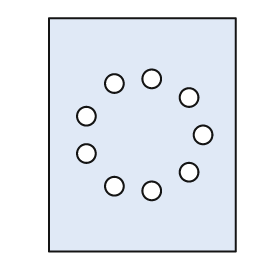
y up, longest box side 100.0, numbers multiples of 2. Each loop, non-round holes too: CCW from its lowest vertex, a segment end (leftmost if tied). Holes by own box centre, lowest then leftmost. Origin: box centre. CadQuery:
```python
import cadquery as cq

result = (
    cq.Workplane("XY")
    .moveTo(-40.0, -50.0)
    .lineTo(40.0, -50.0)
    .lineTo(40.0, 50.0)
    .lineTo(-40.0, 50.0)
    .close()
    .moveTo(4.0, -24.0)
    .circle(4.0)
    .moveTo(-12.0, -22.0)
    .circle(4.0)
    .moveTo(20.0, -16.0)
    .circle(4.0)
    .moveTo(-24.0, -8.0)
    .circle(4.0)
    .moveTo(26.0, 0.0)
    .circle(4.0)
    .moveTo(-24.0, 8.0)
    .circle(4.0)
    .moveTo(20.0, 16.0)
    .circle(4.0)
    .moveTo(-12.0, 22.0)
    .circle(4.0)
    .moveTo(4.0, 24.0)
    .circle(4.0)
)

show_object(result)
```